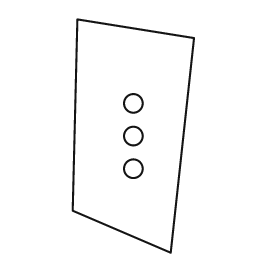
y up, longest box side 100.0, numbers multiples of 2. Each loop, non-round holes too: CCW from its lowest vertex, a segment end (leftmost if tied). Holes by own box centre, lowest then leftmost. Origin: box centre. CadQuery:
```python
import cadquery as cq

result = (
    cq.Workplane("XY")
    .moveTo(16.0, -50.0)
    .lineTo(26.0, 42.0)
    .lineTo(-24.0, 50.0)
    .lineTo(-26.0, -32.0)
    .close()
    .moveTo(0.0, -14.0)
    .circle(4.0)
    .moveTo(0.0, 0.0)
    .circle(4.0)
    .moveTo(0.0, 14.0)
    .circle(4.0)
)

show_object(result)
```